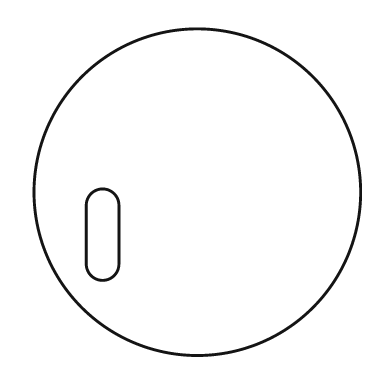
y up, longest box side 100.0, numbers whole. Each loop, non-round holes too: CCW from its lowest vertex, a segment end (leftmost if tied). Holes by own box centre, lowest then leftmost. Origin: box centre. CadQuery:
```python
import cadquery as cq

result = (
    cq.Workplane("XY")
    .moveTo(0.0, 0.0)
    .circle(50.0)
    .moveTo(-34.0, -22.0)
    .threePointArc((-29.0, -27.0), (-24.0, -22.0))
    .lineTo(-24.0, -4.0)
    .threePointArc((-29.0, 1.0), (-34.0, -4.0))
    .close()
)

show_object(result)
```